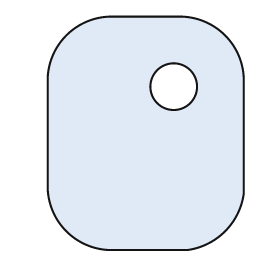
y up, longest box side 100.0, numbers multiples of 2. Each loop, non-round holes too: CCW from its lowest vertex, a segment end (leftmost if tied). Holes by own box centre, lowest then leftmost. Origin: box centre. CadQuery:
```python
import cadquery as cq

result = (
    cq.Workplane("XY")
    .moveTo(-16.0, -50.0)
    .lineTo(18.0, -50.0)
    .threePointArc((34.0, -42.0), (42.0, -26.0))
    .lineTo(42.0, 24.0)
    .threePointArc((34.0, 42.0), (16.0, 50.0))
    .lineTo(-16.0, 50.0)
    .threePointArc((-34.0, 42.0), (-42.0, 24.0))
    .lineTo(-42.0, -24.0)
    .threePointArc((-34.0, -42.0), (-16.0, -50.0))
    .close()
    .moveTo(12.0, 20.0)
    .circle(10.0)
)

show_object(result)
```